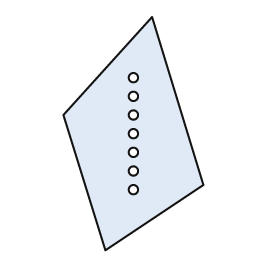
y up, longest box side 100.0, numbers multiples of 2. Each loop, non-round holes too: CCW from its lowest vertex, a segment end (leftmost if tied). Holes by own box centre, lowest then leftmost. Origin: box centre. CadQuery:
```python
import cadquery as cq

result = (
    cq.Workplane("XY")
    .moveTo(-12.0, -50.0)
    .lineTo(30.0, -22.0)
    .lineTo(8.0, 50.0)
    .lineTo(-30.0, 8.0)
    .close()
    .moveTo(0.0, -24.0)
    .circle(2.0)
    .moveTo(0.0, -16.0)
    .circle(2.0)
    .moveTo(0.0, -8.0)
    .circle(2.0)
    .moveTo(0.0, 0.0)
    .circle(2.0)
    .moveTo(0.0, 8.0)
    .circle(2.0)
    .moveTo(0.0, 16.0)
    .circle(2.0)
    .moveTo(0.0, 24.0)
    .circle(2.0)
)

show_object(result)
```